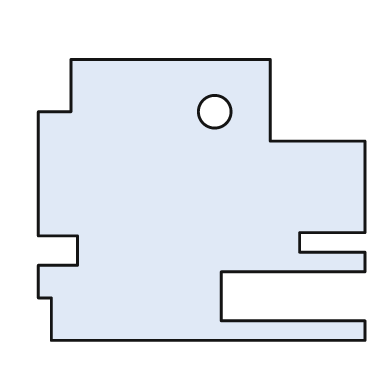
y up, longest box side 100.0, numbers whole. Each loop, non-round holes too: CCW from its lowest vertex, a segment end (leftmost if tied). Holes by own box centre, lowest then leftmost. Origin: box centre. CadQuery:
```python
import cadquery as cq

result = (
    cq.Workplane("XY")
    .moveTo(-46.0, -43.0)
    .lineTo(50.0, -43.0)
    .lineTo(50.0, -37.0)
    .lineTo(6.0, -37.0)
    .lineTo(6.0, -22.0)
    .lineTo(50.0, -22.0)
    .lineTo(50.0, -16.0)
    .lineTo(30.0, -16.0)
    .lineTo(30.0, -10.0)
    .lineTo(50.0, -10.0)
    .lineTo(50.0, 18.0)
    .lineTo(21.0, 18.0)
    .lineTo(21.0, 43.0)
    .lineTo(-40.0, 43.0)
    .lineTo(-40.0, 27.0)
    .lineTo(-50.0, 27.0)
    .lineTo(-50.0, -11.0)
    .lineTo(-38.0, -11.0)
    .lineTo(-38.0, -20.0)
    .lineTo(-50.0, -20.0)
    .lineTo(-50.0, -30.0)
    .lineTo(-46.0, -30.0)
    .close()
    .moveTo(4.0, 27.0)
    .circle(5.0)
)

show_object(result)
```